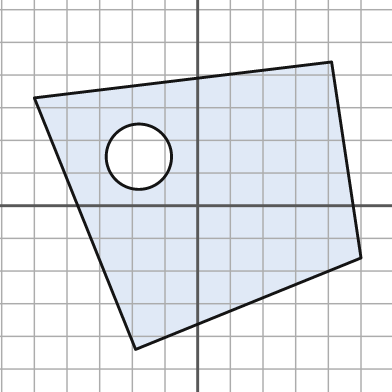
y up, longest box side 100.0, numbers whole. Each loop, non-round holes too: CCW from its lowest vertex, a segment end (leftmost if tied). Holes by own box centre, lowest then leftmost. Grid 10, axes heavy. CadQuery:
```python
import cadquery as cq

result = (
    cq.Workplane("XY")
    .moveTo(-19.0, -44.0)
    .lineTo(50.0, -16.0)
    .lineTo(41.0, 44.0)
    .lineTo(-50.0, 33.0)
    .close()
    .moveTo(-18.0, 15.0)
    .circle(10.0)
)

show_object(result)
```